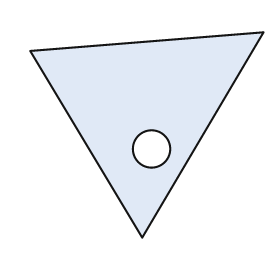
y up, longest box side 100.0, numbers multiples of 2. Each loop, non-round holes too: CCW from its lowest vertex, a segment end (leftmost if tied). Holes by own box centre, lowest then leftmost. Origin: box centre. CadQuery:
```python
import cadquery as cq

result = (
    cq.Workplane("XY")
    .moveTo(-2.0, -44.0)
    .lineTo(50.0, 44.0)
    .lineTo(-50.0, 36.0)
    .close()
    .moveTo(2.0, -6.0)
    .circle(8.0)
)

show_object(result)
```